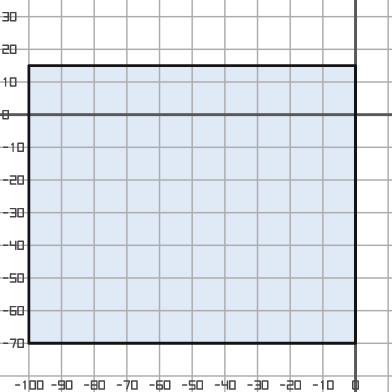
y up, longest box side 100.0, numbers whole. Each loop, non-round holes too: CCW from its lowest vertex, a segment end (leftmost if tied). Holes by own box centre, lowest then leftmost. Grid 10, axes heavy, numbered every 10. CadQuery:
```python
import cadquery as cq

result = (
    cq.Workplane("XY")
    .moveTo(-100.0, -70.0)
    .lineTo(0.0, -70.0)
    .lineTo(0.0, 15.0)
    .lineTo(-100.0, 15.0)
    .close()
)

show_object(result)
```